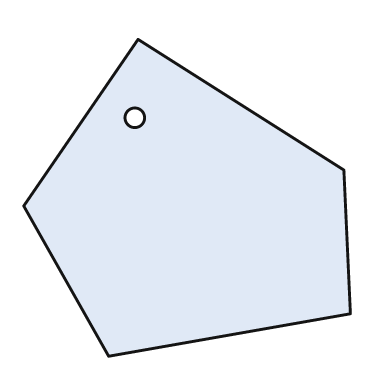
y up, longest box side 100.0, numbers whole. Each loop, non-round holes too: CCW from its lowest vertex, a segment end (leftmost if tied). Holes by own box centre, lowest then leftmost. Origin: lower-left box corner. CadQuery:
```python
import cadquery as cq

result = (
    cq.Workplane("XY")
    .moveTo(26.0, 0.0)
    .lineTo(100.0, 13.0)
    .lineTo(98.0, 57.0)
    .lineTo(35.0, 97.0)
    .lineTo(0.0, 46.0)
    .close()
    .moveTo(34.0, 73.0)
    .circle(3.0)
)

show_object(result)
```